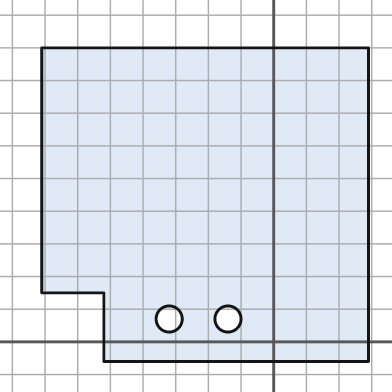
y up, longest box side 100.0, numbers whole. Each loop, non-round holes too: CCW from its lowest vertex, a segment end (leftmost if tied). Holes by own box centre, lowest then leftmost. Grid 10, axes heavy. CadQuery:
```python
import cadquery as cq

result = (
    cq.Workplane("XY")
    .moveTo(-52.0, -6.0)
    .lineTo(29.0, -6.0)
    .lineTo(29.0, 90.0)
    .lineTo(-71.0, 90.0)
    .lineTo(-71.0, 15.0)
    .lineTo(-52.0, 15.0)
    .close()
    .moveTo(-32.0, 7.0)
    .circle(4.0)
    .moveTo(-14.0, 7.0)
    .circle(4.0)
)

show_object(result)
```